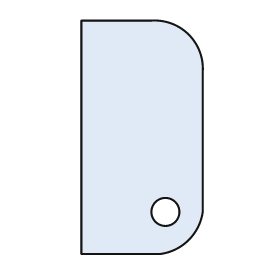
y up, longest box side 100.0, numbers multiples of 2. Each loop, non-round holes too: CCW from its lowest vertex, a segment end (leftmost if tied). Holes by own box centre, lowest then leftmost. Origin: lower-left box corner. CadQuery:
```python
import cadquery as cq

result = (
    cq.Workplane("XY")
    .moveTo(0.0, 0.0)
    .lineTo(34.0, 0.0)
    .threePointArc((46.0, 6.0), (52.0, 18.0))
    .lineTo(52.0, 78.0)
    .threePointArc((46.0, 94.0), (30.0, 100.0))
    .lineTo(0.0, 100.0)
    .close()
    .moveTo(36.0, 18.0)
    .circle(6.0)
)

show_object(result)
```